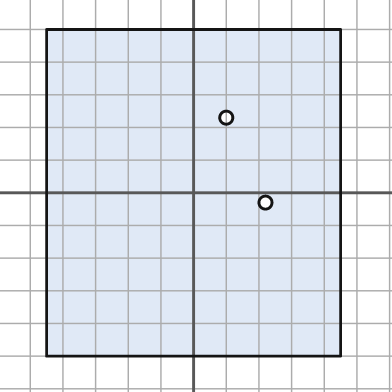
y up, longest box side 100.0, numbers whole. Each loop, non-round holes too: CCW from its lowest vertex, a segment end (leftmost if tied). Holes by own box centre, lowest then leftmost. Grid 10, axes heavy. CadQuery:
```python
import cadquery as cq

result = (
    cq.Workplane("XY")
    .moveTo(-45.0, -50.0)
    .lineTo(45.0, -50.0)
    .lineTo(45.0, 50.0)
    .lineTo(-45.0, 50.0)
    .close()
    .moveTo(22.0, -3.0)
    .circle(2.0)
    .moveTo(10.0, 23.0)
    .circle(2.0)
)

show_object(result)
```